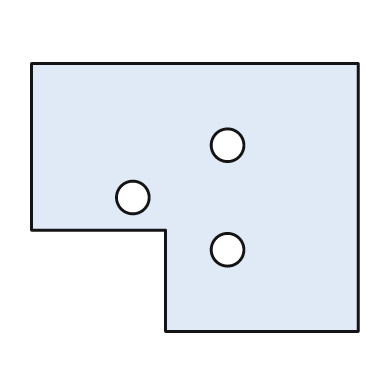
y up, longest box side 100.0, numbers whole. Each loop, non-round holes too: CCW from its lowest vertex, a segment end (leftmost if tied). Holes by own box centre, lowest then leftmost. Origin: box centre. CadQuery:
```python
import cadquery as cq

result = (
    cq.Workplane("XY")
    .moveTo(-9.0, -41.0)
    .lineTo(50.0, -41.0)
    .lineTo(50.0, 41.0)
    .lineTo(-50.0, 41.0)
    .lineTo(-50.0, -10.0)
    .lineTo(-9.0, -10.0)
    .close()
    .moveTo(10.0, -16.0)
    .circle(5.0)
    .moveTo(-19.0, 0.0)
    .circle(5.0)
    .moveTo(10.0, 16.0)
    .circle(5.0)
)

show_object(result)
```